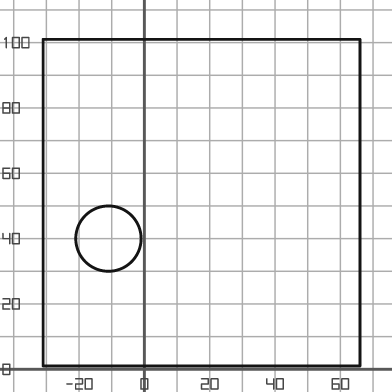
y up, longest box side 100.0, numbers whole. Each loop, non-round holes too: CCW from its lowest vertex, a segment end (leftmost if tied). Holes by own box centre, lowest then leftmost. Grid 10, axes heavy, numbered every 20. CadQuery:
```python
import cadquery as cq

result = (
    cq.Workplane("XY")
    .moveTo(-31.0, 1.0)
    .lineTo(66.0, 1.0)
    .lineTo(66.0, 101.0)
    .lineTo(-31.0, 101.0)
    .close()
    .moveTo(-11.0, 40.0)
    .circle(10.0)
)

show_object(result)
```